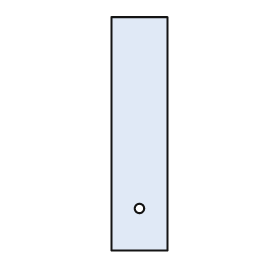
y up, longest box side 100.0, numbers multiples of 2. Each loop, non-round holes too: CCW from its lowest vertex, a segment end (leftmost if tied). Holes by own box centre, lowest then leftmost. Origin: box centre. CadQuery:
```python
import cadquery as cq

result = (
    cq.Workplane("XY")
    .moveTo(-12.0, -50.0)
    .lineTo(12.0, -50.0)
    .lineTo(12.0, 50.0)
    .lineTo(-12.0, 50.0)
    .close()
    .moveTo(0.0, -32.0)
    .circle(2.0)
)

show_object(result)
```